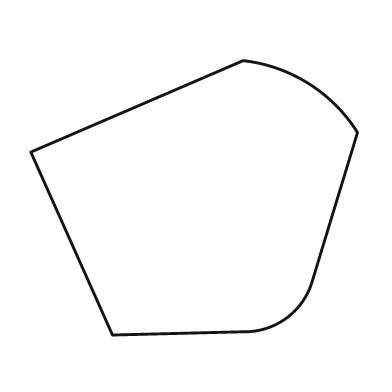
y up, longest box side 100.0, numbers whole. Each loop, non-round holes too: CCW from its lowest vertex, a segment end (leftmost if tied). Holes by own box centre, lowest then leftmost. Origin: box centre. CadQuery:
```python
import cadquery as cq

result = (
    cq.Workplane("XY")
    .moveTo(-25.0, -42.0)
    .lineTo(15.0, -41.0)
    .threePointArc((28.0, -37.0), (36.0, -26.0))
    .lineTo(50.0, 20.0)
    .threePointArc((35.0, 35.0), (15.0, 42.0))
    .lineTo(-50.0, 14.0)
    .close()
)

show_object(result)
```